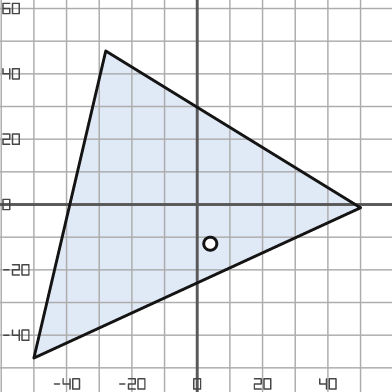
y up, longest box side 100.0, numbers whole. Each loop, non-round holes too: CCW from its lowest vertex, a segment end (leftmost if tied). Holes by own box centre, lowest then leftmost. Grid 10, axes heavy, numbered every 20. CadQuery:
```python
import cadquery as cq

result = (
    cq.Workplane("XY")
    .moveTo(-50.0, -47.0)
    .lineTo(50.0, -1.0)
    .lineTo(-28.0, 47.0)
    .close()
    .moveTo(4.0, -12.0)
    .circle(2.0)
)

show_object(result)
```